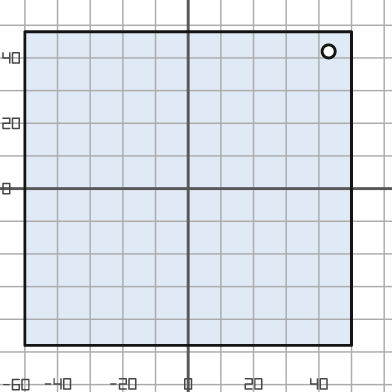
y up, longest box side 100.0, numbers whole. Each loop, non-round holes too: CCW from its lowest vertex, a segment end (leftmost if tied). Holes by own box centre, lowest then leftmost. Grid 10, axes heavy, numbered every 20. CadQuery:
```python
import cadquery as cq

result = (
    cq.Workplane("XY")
    .moveTo(-50.0, -48.0)
    .lineTo(50.0, -48.0)
    .lineTo(50.0, 48.0)
    .lineTo(-50.0, 48.0)
    .close()
    .moveTo(43.0, 42.0)
    .circle(2.0)
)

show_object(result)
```